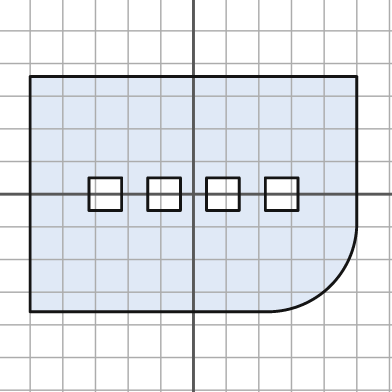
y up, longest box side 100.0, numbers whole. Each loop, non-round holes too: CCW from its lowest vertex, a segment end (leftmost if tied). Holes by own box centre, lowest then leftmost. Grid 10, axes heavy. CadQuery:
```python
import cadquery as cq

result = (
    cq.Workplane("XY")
    .moveTo(-50.0, -36.0)
    .lineTo(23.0, -36.0)
    .threePointArc((42.0, -28.0), (50.0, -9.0))
    .lineTo(50.0, 36.0)
    .lineTo(-50.0, 36.0)
    .close()
    .moveTo(-32.0, -5.0)
    .lineTo(-22.0, -5.0)
    .lineTo(-22.0, 5.0)
    .lineTo(-32.0, 5.0)
    .close()
    .moveTo(-14.0, -5.0)
    .lineTo(-4.0, -5.0)
    .lineTo(-4.0, 5.0)
    .lineTo(-14.0, 5.0)
    .close()
    .moveTo(4.0, -5.0)
    .lineTo(14.0, -5.0)
    .lineTo(14.0, 5.0)
    .lineTo(4.0, 5.0)
    .close()
    .moveTo(22.0, -5.0)
    .lineTo(32.0, -5.0)
    .lineTo(32.0, 5.0)
    .lineTo(22.0, 5.0)
    .close()
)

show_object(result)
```